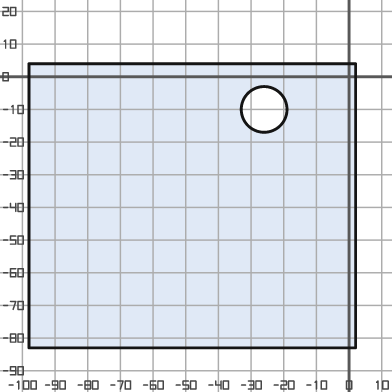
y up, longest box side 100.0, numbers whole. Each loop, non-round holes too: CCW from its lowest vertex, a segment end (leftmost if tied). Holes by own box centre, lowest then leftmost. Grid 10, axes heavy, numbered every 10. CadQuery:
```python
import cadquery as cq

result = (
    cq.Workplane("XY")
    .moveTo(-98.0, -83.0)
    .lineTo(2.0, -83.0)
    .lineTo(2.0, 4.0)
    .lineTo(-98.0, 4.0)
    .close()
    .moveTo(-26.0, -10.0)
    .circle(7.0)
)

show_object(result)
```